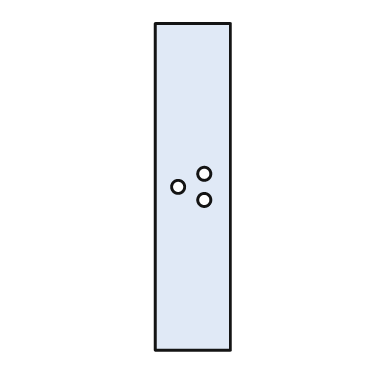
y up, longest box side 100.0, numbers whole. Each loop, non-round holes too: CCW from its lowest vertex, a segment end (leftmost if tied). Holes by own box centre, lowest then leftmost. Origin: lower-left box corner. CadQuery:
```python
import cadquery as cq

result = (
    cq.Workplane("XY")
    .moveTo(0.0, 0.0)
    .lineTo(23.0, 0.0)
    .lineTo(23.0, 100.0)
    .lineTo(0.0, 100.0)
    .close()
    .moveTo(15.0, 46.0)
    .circle(2.0)
    .moveTo(7.0, 50.0)
    .circle(2.0)
    .moveTo(15.0, 54.0)
    .circle(2.0)
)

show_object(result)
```